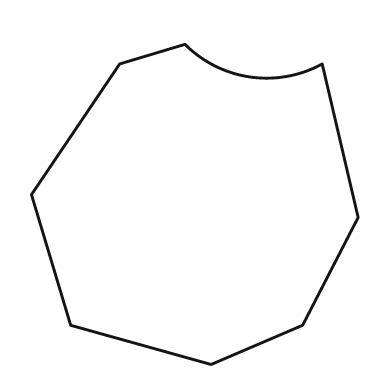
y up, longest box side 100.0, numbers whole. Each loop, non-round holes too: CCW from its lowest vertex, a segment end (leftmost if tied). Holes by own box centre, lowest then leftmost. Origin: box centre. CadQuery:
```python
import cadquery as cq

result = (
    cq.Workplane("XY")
    .moveTo(5.0, -49.0)
    .lineTo(33.0, -37.0)
    .lineTo(50.0, -4.0)
    .lineTo(39.0, 43.0)
    .threePointArc((17.0, 39.0), (-3.0, 49.0))
    .lineTo(-23.0, 43.0)
    .lineTo(-50.0, 3.0)
    .lineTo(-38.0, -37.0)
    .close()
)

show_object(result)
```